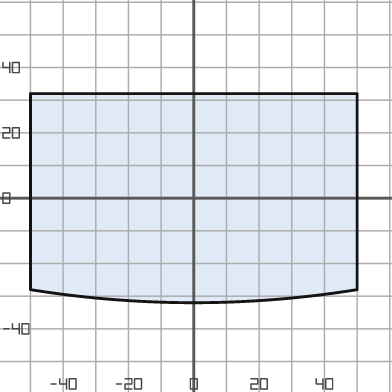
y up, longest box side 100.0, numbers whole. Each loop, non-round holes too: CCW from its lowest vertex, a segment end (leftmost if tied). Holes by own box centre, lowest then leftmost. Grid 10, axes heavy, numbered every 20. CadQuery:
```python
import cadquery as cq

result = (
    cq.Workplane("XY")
    .moveTo(-50.0, -28.0)
    .threePointArc((0.0, -32.0), (50.0, -28.0))
    .lineTo(50.0, 32.0)
    .lineTo(-50.0, 32.0)
    .close()
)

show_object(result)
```